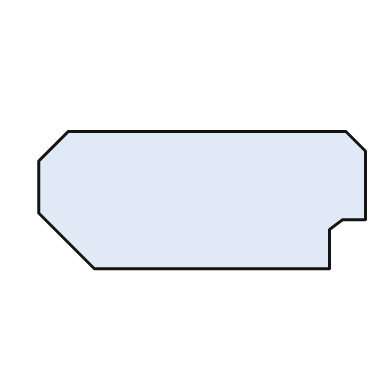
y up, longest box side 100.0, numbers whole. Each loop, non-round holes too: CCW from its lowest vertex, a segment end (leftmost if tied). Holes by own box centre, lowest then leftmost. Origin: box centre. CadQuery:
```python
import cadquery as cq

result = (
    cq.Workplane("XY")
    .moveTo(-33.0, -21.0)
    .lineTo(39.0, -21.0)
    .lineTo(39.0, -9.0)
    .lineTo(43.0, -6.0)
    .lineTo(50.0, -6.0)
    .lineTo(50.0, 15.0)
    .lineTo(44.0, 21.0)
    .lineTo(-41.0, 21.0)
    .lineTo(-50.0, 12.0)
    .lineTo(-50.0, -4.0)
    .close()
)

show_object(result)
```